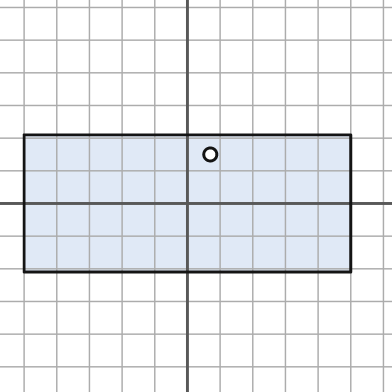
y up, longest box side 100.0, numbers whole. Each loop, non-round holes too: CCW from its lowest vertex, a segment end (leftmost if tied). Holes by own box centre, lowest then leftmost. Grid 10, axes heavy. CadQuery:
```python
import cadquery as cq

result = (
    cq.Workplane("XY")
    .moveTo(-50.0, -21.0)
    .lineTo(50.0, -21.0)
    .lineTo(50.0, 21.0)
    .lineTo(-50.0, 21.0)
    .close()
    .moveTo(7.0, 15.0)
    .circle(2.0)
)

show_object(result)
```